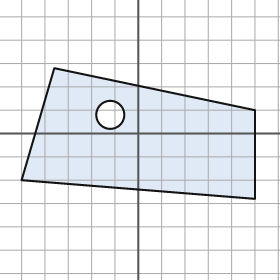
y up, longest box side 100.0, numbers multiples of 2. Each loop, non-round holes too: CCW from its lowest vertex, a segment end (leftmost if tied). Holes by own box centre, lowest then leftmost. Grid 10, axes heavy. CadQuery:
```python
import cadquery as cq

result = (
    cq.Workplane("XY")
    .moveTo(50.0, -28.0)
    .lineTo(50.0, 10.0)
    .lineTo(-36.0, 28.0)
    .lineTo(-50.0, -20.0)
    .close()
    .moveTo(-12.0, 8.0)
    .circle(6.0)
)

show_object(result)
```